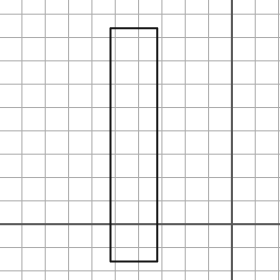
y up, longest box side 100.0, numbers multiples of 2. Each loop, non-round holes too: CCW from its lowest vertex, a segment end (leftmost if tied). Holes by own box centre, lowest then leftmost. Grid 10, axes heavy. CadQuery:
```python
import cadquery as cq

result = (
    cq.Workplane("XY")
    .moveTo(-52.0, -16.0)
    .lineTo(-32.0, -16.0)
    .lineTo(-32.0, 84.0)
    .lineTo(-52.0, 84.0)
    .close()
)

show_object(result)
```